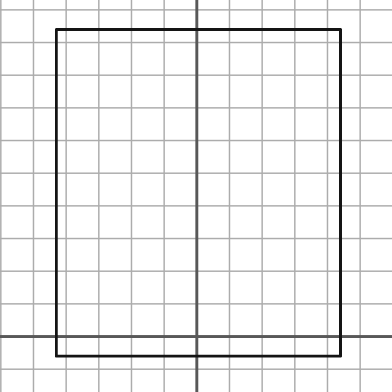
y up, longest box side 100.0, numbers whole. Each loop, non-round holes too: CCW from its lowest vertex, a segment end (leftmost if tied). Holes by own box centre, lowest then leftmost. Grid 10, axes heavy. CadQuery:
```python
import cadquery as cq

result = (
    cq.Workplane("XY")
    .moveTo(-43.0, -6.0)
    .lineTo(44.0, -6.0)
    .lineTo(44.0, 94.0)
    .lineTo(-43.0, 94.0)
    .close()
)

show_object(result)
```